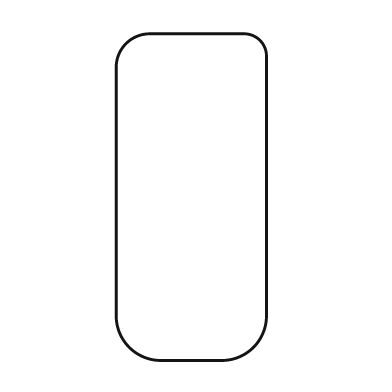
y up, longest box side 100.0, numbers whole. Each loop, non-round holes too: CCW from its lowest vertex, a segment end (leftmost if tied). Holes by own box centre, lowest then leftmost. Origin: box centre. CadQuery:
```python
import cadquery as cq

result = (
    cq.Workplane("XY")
    .moveTo(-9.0, -50.0)
    .lineTo(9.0, -50.0)
    .threePointArc((19.0, -46.0), (23.0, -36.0))
    .lineTo(23.0, 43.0)
    .threePointArc((21.0, 48.0), (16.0, 50.0))
    .lineTo(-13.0, 50.0)
    .threePointArc((-20.0, 47.0), (-23.0, 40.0))
    .lineTo(-23.0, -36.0)
    .threePointArc((-19.0, -46.0), (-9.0, -50.0))
    .close()
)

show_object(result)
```